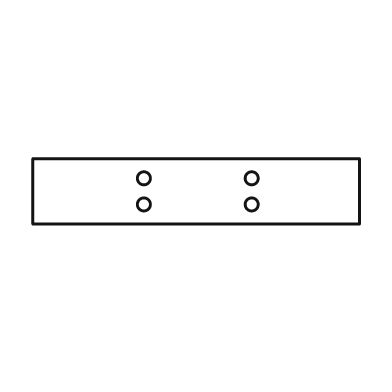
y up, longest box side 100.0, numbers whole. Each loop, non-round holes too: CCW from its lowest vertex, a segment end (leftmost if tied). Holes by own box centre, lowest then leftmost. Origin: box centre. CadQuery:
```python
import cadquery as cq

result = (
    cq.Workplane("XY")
    .moveTo(-50.0, -10.0)
    .lineTo(50.0, -10.0)
    .lineTo(50.0, 10.0)
    .lineTo(-50.0, 10.0)
    .close()
    .moveTo(-16.0, -4.0)
    .circle(2.0)
    .moveTo(17.0, -4.0)
    .circle(2.0)
    .moveTo(-16.0, 4.0)
    .circle(2.0)
    .moveTo(17.0, 4.0)
    .circle(2.0)
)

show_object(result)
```